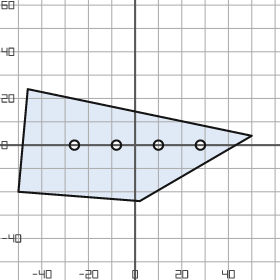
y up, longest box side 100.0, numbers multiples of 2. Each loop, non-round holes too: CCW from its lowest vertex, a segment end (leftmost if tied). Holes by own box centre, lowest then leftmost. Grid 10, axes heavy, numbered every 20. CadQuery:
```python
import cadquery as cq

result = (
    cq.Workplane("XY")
    .moveTo(2.0, -24.0)
    .lineTo(50.0, 4.0)
    .lineTo(-46.0, 24.0)
    .lineTo(-50.0, -20.0)
    .close()
    .moveTo(-26.0, 0.0)
    .circle(2.0)
    .moveTo(-8.0, 0.0)
    .circle(2.0)
    .moveTo(10.0, 0.0)
    .circle(2.0)
    .moveTo(28.0, 0.0)
    .circle(2.0)
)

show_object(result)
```